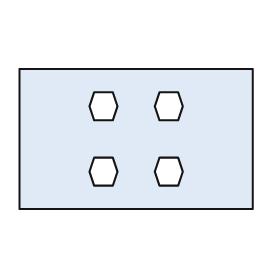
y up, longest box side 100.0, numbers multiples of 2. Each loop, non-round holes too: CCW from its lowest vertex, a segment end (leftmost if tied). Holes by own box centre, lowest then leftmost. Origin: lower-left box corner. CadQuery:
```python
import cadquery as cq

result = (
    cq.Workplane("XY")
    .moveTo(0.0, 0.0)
    .lineTo(100.0, 0.0)
    .lineTo(100.0, 60.0)
    .lineTo(0.0, 60.0)
    .close()
    .moveTo(32.0, 10.0)
    .lineTo(40.0, 10.0)
    .lineTo(42.0, 16.0)
    .lineTo(40.0, 22.0)
    .lineTo(32.0, 22.0)
    .lineTo(30.0, 16.0)
    .close()
    .moveTo(60.0, 10.0)
    .lineTo(68.0, 10.0)
    .lineTo(70.0, 16.0)
    .lineTo(68.0, 22.0)
    .lineTo(60.0, 22.0)
    .lineTo(58.0, 16.0)
    .close()
    .moveTo(32.0, 38.0)
    .lineTo(40.0, 38.0)
    .lineTo(42.0, 44.0)
    .lineTo(40.0, 50.0)
    .lineTo(32.0, 50.0)
    .lineTo(30.0, 44.0)
    .close()
    .moveTo(60.0, 38.0)
    .lineTo(68.0, 38.0)
    .lineTo(70.0, 44.0)
    .lineTo(68.0, 50.0)
    .lineTo(60.0, 50.0)
    .lineTo(58.0, 44.0)
    .close()
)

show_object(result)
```